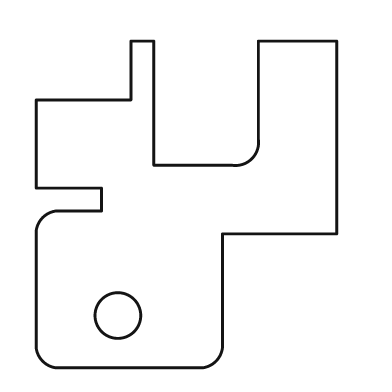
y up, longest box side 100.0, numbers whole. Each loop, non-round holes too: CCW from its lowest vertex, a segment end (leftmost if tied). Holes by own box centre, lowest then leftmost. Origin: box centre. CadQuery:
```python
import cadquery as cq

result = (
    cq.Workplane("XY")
    .moveTo(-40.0, -50.0)
    .lineTo(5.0, -50.0)
    .threePointArc((9.0, -48.0), (11.0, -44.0))
    .lineTo(11.0, -9.0)
    .lineTo(46.0, -9.0)
    .lineTo(46.0, 50.0)
    .lineTo(22.0, 50.0)
    .lineTo(22.0, 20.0)
    .threePointArc((20.0, 14.0), (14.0, 12.0))
    .lineTo(-10.0, 12.0)
    .lineTo(-10.0, 50.0)
    .lineTo(-17.0, 50.0)
    .lineTo(-17.0, 32.0)
    .lineTo(-46.0, 32.0)
    .lineTo(-46.0, 5.0)
    .lineTo(-26.0, 5.0)
    .lineTo(-26.0, -2.0)
    .lineTo(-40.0, -2.0)
    .threePointArc((-44.0, -4.0), (-46.0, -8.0))
    .lineTo(-46.0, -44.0)
    .threePointArc((-44.0, -48.0), (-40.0, -50.0))
    .close()
    .moveTo(-21.0, -34.0)
    .circle(7.0)
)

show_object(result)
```